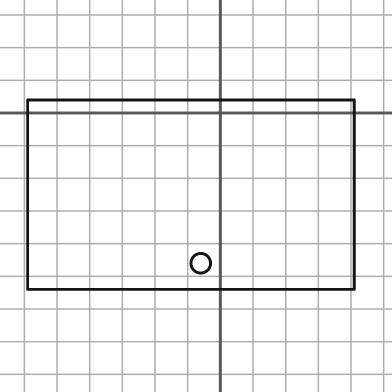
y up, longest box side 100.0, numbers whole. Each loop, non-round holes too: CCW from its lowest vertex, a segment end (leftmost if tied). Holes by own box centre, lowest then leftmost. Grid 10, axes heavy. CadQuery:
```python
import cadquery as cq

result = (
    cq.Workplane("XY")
    .moveTo(-59.0, -54.0)
    .lineTo(41.0, -54.0)
    .lineTo(41.0, 4.0)
    .lineTo(-59.0, 4.0)
    .close()
    .moveTo(-6.0, -46.0)
    .circle(3.0)
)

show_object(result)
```